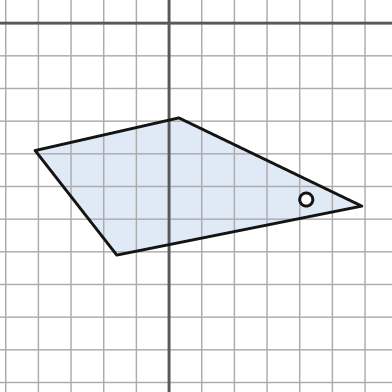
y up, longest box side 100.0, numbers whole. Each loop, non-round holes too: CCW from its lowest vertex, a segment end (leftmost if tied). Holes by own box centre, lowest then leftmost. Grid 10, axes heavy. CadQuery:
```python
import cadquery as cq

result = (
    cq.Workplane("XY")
    .moveTo(-16.0, -71.0)
    .lineTo(59.0, -56.0)
    .lineTo(3.0, -29.0)
    .lineTo(-41.0, -39.0)
    .close()
    .moveTo(42.0, -54.0)
    .circle(2.0)
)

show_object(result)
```